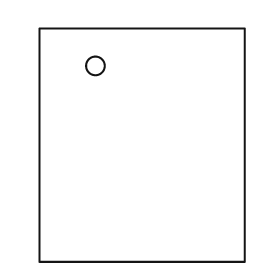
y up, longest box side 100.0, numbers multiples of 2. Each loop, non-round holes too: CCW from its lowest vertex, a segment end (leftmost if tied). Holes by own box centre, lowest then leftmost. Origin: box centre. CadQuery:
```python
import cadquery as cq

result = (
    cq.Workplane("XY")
    .moveTo(-44.0, -50.0)
    .lineTo(44.0, -50.0)
    .lineTo(44.0, 50.0)
    .lineTo(-44.0, 50.0)
    .close()
    .moveTo(-20.0, 34.0)
    .circle(4.0)
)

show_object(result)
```